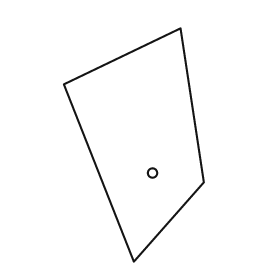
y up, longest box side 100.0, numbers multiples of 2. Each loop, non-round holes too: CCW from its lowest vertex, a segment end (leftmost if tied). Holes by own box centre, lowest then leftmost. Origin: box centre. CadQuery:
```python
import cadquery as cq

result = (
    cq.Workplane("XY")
    .moveTo(0.0, -50.0)
    .lineTo(30.0, -16.0)
    .lineTo(20.0, 50.0)
    .lineTo(-30.0, 26.0)
    .close()
    .moveTo(8.0, -12.0)
    .circle(2.0)
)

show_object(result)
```